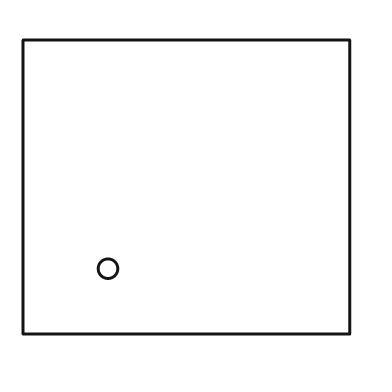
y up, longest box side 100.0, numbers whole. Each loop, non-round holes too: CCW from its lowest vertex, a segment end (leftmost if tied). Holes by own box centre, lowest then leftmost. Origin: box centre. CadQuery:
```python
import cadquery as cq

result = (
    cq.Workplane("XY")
    .moveTo(-50.0, -45.0)
    .lineTo(50.0, -45.0)
    .lineTo(50.0, 45.0)
    .lineTo(-50.0, 45.0)
    .close()
    .moveTo(-24.0, -25.0)
    .circle(3.0)
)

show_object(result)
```